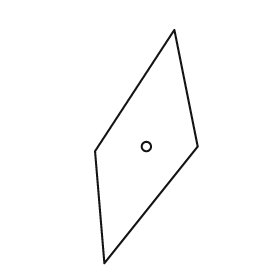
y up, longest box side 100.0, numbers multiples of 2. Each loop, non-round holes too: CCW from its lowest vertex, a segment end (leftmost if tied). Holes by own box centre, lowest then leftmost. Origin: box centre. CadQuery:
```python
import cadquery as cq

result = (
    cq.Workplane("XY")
    .moveTo(-18.0, -50.0)
    .lineTo(22.0, 0.0)
    .lineTo(12.0, 50.0)
    .lineTo(-22.0, -2.0)
    .close()
    .moveTo(0.0, 0.0)
    .circle(2.0)
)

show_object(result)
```